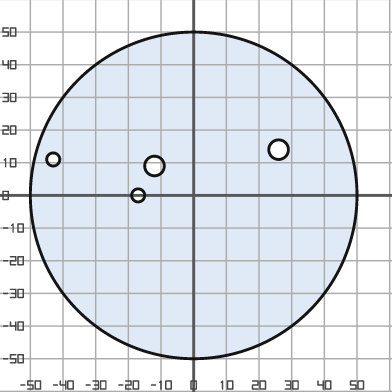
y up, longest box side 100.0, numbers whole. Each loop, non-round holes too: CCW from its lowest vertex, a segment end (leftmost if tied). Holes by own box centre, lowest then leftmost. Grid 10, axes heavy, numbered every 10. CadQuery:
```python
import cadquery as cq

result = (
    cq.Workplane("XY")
    .moveTo(0.0, 0.0)
    .circle(50.0)
    .moveTo(-17.0, 0.0)
    .circle(2.0)
    .moveTo(-12.0, 9.0)
    .circle(3.0)
    .moveTo(-43.0, 11.0)
    .circle(2.0)
    .moveTo(26.0, 14.0)
    .circle(3.0)
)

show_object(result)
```